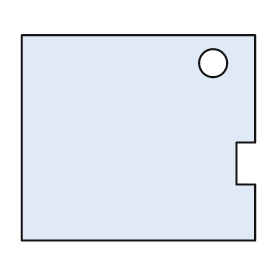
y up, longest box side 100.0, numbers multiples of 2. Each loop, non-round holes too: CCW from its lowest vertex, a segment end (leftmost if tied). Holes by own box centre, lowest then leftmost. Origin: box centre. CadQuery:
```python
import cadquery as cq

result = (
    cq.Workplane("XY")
    .moveTo(-50.0, -44.0)
    .lineTo(50.0, -44.0)
    .lineTo(50.0, -20.0)
    .lineTo(42.0, -20.0)
    .lineTo(42.0, -2.0)
    .lineTo(50.0, -2.0)
    .lineTo(50.0, 44.0)
    .lineTo(-50.0, 44.0)
    .close()
    .moveTo(32.0, 32.0)
    .circle(6.0)
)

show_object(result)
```